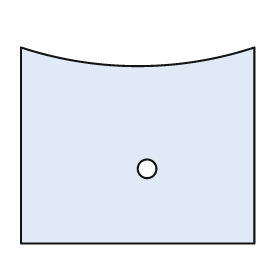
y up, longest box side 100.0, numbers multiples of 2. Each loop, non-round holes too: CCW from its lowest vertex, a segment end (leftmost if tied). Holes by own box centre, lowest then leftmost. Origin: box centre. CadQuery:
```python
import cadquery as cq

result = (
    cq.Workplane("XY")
    .moveTo(-50.0, -42.0)
    .lineTo(50.0, -42.0)
    .lineTo(50.0, 42.0)
    .threePointArc((0.0, 34.0), (-50.0, 42.0))
    .close()
    .moveTo(4.0, -10.0)
    .circle(4.0)
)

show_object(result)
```